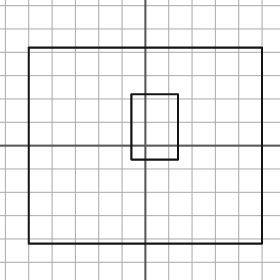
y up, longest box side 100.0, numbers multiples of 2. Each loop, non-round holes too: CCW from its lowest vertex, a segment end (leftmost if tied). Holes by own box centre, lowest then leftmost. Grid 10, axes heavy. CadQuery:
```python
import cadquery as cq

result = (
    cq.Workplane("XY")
    .moveTo(-50.0, -42.0)
    .lineTo(50.0, -42.0)
    .lineTo(50.0, 42.0)
    .lineTo(-50.0, 42.0)
    .close()
    .moveTo(-6.0, -6.0)
    .lineTo(14.0, -6.0)
    .lineTo(14.0, 22.0)
    .lineTo(-6.0, 22.0)
    .close()
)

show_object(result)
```